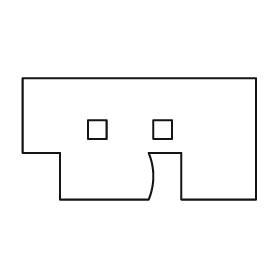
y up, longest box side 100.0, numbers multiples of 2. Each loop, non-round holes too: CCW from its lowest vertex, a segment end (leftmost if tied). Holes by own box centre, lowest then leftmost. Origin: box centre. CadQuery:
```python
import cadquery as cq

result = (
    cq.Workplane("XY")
    .moveTo(-34.0, -26.0)
    .lineTo(4.0, -26.0)
    .threePointArc((6.0, -16.0), (4.0, -6.0))
    .lineTo(18.0, -6.0)
    .lineTo(18.0, -26.0)
    .lineTo(50.0, -26.0)
    .lineTo(50.0, 26.0)
    .lineTo(-50.0, 26.0)
    .lineTo(-50.0, -6.0)
    .lineTo(-34.0, -6.0)
    .close()
    .moveTo(-22.0, 0.0)
    .lineTo(-14.0, 0.0)
    .lineTo(-14.0, 8.0)
    .lineTo(-22.0, 8.0)
    .close()
    .moveTo(6.0, 0.0)
    .lineTo(14.0, 0.0)
    .lineTo(14.0, 8.0)
    .lineTo(6.0, 8.0)
    .close()
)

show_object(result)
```